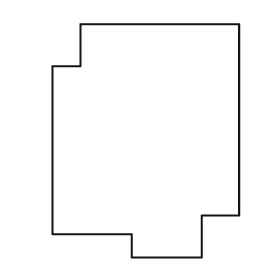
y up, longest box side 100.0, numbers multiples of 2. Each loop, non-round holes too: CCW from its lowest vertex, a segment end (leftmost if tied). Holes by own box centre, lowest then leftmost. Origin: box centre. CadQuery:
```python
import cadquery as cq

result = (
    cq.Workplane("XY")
    .moveTo(-6.0, -50.0)
    .lineTo(24.0, -50.0)
    .lineTo(24.0, -32.0)
    .lineTo(40.0, -32.0)
    .lineTo(40.0, 50.0)
    .lineTo(-28.0, 50.0)
    .lineTo(-28.0, 32.0)
    .lineTo(-40.0, 32.0)
    .lineTo(-40.0, -40.0)
    .lineTo(-6.0, -40.0)
    .close()
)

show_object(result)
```